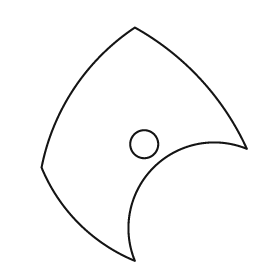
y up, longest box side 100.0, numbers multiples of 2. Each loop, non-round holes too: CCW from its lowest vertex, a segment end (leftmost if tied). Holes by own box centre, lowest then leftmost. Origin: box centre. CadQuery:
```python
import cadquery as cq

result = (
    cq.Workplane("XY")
    .moveTo(-4.0, -50.0)
    .threePointArc((4.0, -10.0), (44.0, -2.0))
    .threePointArc((24.0, 28.0), (-4.0, 50.0))
    .threePointArc((-30.0, 24.0), (-44.0, -10.0))
    .threePointArc((-28.0, -34.0), (-4.0, -50.0))
    .close()
    .moveTo(0.0, 0.0)
    .circle(6.0)
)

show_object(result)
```